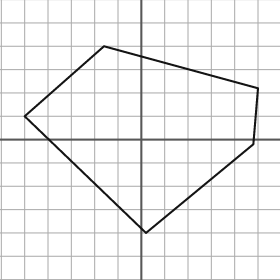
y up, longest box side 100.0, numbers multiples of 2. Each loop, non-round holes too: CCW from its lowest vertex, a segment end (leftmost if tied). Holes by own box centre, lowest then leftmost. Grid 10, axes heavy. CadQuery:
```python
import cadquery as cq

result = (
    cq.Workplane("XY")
    .moveTo(2.0, -40.0)
    .lineTo(48.0, -2.0)
    .lineTo(50.0, 22.0)
    .lineTo(-16.0, 40.0)
    .lineTo(-50.0, 10.0)
    .close()
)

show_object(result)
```